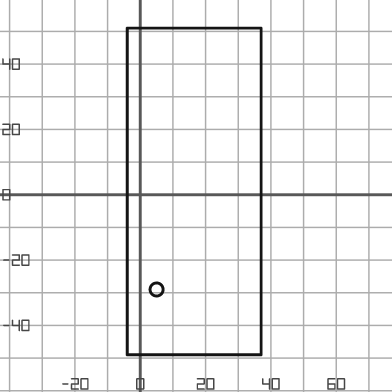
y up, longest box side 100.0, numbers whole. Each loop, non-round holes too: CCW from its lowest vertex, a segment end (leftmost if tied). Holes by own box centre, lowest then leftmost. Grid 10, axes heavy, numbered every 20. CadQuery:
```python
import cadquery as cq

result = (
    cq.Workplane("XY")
    .moveTo(-4.0, -49.0)
    .lineTo(37.0, -49.0)
    .lineTo(37.0, 51.0)
    .lineTo(-4.0, 51.0)
    .close()
    .moveTo(5.0, -29.0)
    .circle(2.0)
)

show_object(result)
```